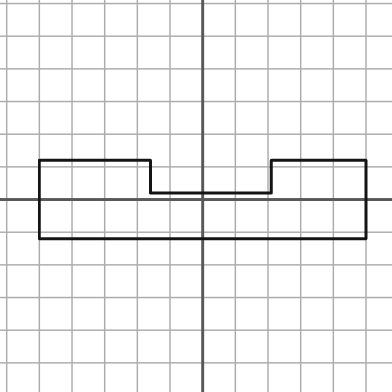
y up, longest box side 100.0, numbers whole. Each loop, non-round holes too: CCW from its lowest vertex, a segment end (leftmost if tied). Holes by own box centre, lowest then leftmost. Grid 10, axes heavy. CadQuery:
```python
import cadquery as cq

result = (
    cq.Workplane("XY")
    .moveTo(-50.0, -12.0)
    .lineTo(50.0, -12.0)
    .lineTo(50.0, 12.0)
    .lineTo(21.0, 12.0)
    .lineTo(21.0, 2.0)
    .lineTo(-16.0, 2.0)
    .lineTo(-16.0, 12.0)
    .lineTo(-50.0, 12.0)
    .close()
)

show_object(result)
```